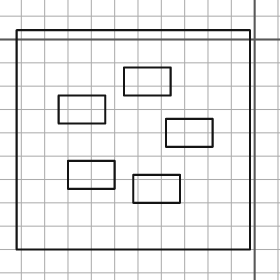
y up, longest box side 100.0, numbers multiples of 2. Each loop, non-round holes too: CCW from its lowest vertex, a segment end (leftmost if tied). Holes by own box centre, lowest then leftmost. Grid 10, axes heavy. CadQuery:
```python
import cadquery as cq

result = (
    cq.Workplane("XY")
    .moveTo(-102.0, -90.0)
    .lineTo(-2.0, -90.0)
    .lineTo(-2.0, 4.0)
    .lineTo(-102.0, 4.0)
    .close()
    .moveTo(-52.0, -70.0)
    .lineTo(-32.0, -70.0)
    .lineTo(-32.0, -58.0)
    .lineTo(-52.0, -58.0)
    .close()
    .moveTo(-80.0, -64.0)
    .lineTo(-60.0, -64.0)
    .lineTo(-60.0, -52.0)
    .lineTo(-80.0, -52.0)
    .close()
    .moveTo(-38.0, -46.0)
    .lineTo(-18.0, -46.0)
    .lineTo(-18.0, -34.0)
    .lineTo(-38.0, -34.0)
    .close()
    .moveTo(-84.0, -36.0)
    .lineTo(-64.0, -36.0)
    .lineTo(-64.0, -24.0)
    .lineTo(-84.0, -24.0)
    .close()
    .moveTo(-56.0, -24.0)
    .lineTo(-36.0, -24.0)
    .lineTo(-36.0, -12.0)
    .lineTo(-56.0, -12.0)
    .close()
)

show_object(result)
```